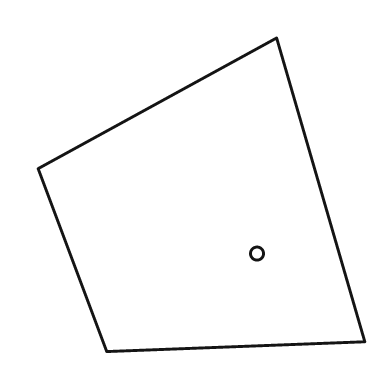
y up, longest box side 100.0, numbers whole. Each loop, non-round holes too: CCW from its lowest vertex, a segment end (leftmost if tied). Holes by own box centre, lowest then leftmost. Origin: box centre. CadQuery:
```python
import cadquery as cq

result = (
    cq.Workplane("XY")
    .moveTo(-29.0, -48.0)
    .lineTo(50.0, -45.0)
    .lineTo(23.0, 48.0)
    .lineTo(-50.0, 8.0)
    .close()
    .moveTo(17.0, -18.0)
    .circle(2.0)
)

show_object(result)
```